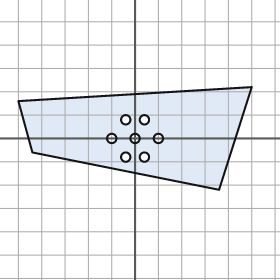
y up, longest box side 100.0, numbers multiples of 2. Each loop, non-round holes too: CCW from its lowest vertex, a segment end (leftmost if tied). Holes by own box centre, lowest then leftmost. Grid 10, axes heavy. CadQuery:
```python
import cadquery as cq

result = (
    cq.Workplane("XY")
    .moveTo(36.0, -22.0)
    .lineTo(50.0, 22.0)
    .lineTo(-50.0, 16.0)
    .lineTo(-44.0, -6.0)
    .close()
    .moveTo(-4.0, -8.0)
    .circle(2.0)
    .moveTo(4.0, -8.0)
    .circle(2.0)
    .moveTo(-10.0, 0.0)
    .circle(2.0)
    .moveTo(0.0, 0.0)
    .circle(2.0)
    .moveTo(10.0, 0.0)
    .circle(2.0)
    .moveTo(-4.0, 8.0)
    .circle(2.0)
    .moveTo(4.0, 8.0)
    .circle(2.0)
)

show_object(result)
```